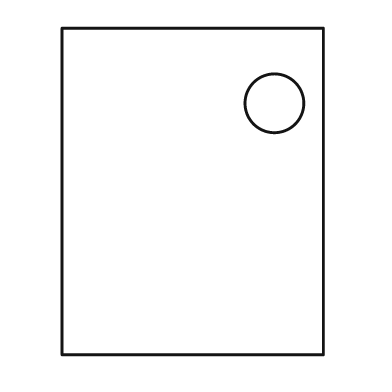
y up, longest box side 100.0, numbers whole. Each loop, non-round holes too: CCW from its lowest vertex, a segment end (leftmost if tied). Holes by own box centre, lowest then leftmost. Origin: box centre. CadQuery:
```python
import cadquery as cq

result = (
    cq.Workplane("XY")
    .moveTo(-40.0, -50.0)
    .lineTo(40.0, -50.0)
    .lineTo(40.0, 50.0)
    .lineTo(-40.0, 50.0)
    .close()
    .moveTo(25.0, 27.0)
    .circle(9.0)
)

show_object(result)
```